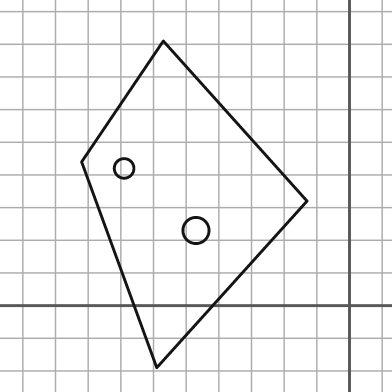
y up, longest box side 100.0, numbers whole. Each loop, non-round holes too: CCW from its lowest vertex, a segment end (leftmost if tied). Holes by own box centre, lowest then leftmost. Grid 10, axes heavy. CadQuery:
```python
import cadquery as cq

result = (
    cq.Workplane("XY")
    .moveTo(-59.0, -19.0)
    .lineTo(-13.0, 32.0)
    .lineTo(-57.0, 81.0)
    .lineTo(-82.0, 44.0)
    .close()
    .moveTo(-47.0, 23.0)
    .circle(4.0)
    .moveTo(-69.0, 42.0)
    .circle(3.0)
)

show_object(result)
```